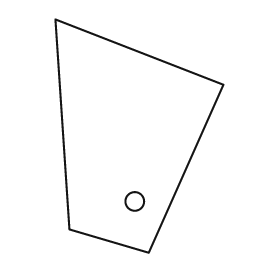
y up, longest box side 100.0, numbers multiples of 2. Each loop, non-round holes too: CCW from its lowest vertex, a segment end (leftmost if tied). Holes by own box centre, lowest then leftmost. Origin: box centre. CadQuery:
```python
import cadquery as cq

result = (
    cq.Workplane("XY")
    .moveTo(4.0, -50.0)
    .lineTo(36.0, 22.0)
    .lineTo(-36.0, 50.0)
    .lineTo(-30.0, -40.0)
    .close()
    .moveTo(-2.0, -28.0)
    .circle(4.0)
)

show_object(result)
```